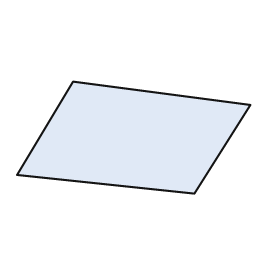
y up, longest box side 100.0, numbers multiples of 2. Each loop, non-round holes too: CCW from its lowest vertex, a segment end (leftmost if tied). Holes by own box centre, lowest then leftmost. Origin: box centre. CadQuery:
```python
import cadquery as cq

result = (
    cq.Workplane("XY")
    .moveTo(26.0, -24.0)
    .lineTo(50.0, 14.0)
    .lineTo(-26.0, 24.0)
    .lineTo(-50.0, -16.0)
    .close()
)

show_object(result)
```